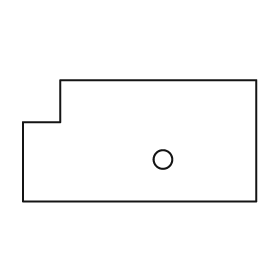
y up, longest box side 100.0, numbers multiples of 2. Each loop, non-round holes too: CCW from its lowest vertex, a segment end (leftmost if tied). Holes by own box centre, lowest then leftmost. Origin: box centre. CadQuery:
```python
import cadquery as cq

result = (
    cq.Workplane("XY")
    .moveTo(-50.0, -26.0)
    .lineTo(50.0, -26.0)
    .lineTo(50.0, 26.0)
    .lineTo(-34.0, 26.0)
    .lineTo(-34.0, 8.0)
    .lineTo(-50.0, 8.0)
    .close()
    .moveTo(10.0, -8.0)
    .circle(4.0)
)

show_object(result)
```